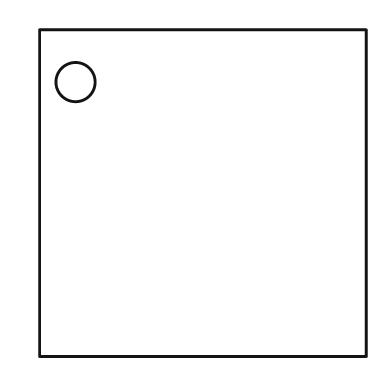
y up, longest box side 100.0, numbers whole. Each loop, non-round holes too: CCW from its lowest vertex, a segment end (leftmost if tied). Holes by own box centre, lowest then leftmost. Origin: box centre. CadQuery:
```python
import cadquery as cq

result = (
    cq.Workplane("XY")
    .moveTo(-50.0, -50.0)
    .lineTo(50.0, -50.0)
    .lineTo(50.0, 50.0)
    .lineTo(-50.0, 50.0)
    .close()
    .moveTo(-39.0, 34.0)
    .circle(6.0)
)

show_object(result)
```